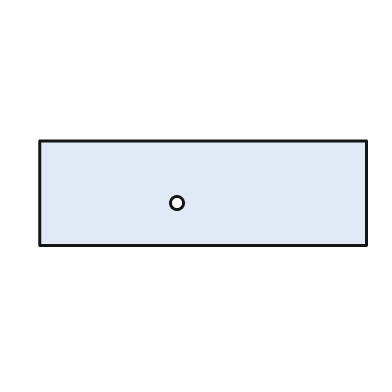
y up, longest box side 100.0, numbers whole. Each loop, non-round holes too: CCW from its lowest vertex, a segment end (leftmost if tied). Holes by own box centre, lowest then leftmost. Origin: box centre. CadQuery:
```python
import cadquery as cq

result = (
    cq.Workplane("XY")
    .moveTo(-50.0, -16.0)
    .lineTo(50.0, -16.0)
    .lineTo(50.0, 16.0)
    .lineTo(-50.0, 16.0)
    .close()
    .moveTo(-8.0, -3.0)
    .circle(2.0)
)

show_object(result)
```